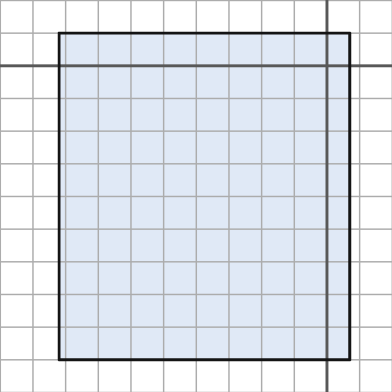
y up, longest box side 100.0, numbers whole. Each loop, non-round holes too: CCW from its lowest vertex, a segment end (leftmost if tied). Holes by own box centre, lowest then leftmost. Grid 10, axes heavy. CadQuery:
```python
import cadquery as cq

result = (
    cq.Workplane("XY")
    .moveTo(-82.0, -90.0)
    .lineTo(7.0, -90.0)
    .lineTo(7.0, 10.0)
    .lineTo(-82.0, 10.0)
    .close()
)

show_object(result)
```